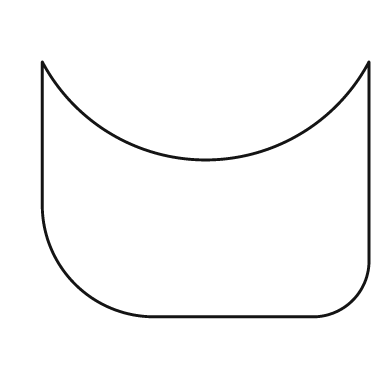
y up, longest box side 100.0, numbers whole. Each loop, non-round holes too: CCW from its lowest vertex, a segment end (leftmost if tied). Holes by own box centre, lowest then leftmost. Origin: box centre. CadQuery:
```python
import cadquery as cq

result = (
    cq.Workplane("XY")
    .moveTo(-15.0, -39.0)
    .lineTo(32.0, -39.0)
    .threePointArc((45.0, -34.0), (50.0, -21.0))
    .lineTo(50.0, 39.0)
    .threePointArc((0.0, 9.0), (-50.0, 39.0))
    .lineTo(-50.0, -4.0)
    .threePointArc((-40.0, -29.0), (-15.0, -39.0))
    .close()
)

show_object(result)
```